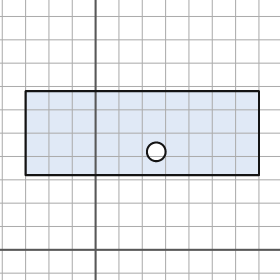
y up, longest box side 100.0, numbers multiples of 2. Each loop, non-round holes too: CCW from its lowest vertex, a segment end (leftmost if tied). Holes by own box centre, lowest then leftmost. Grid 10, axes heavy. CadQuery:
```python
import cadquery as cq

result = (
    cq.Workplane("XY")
    .moveTo(-30.0, 32.0)
    .lineTo(70.0, 32.0)
    .lineTo(70.0, 68.0)
    .lineTo(-30.0, 68.0)
    .close()
    .moveTo(26.0, 42.0)
    .circle(4.0)
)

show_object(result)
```